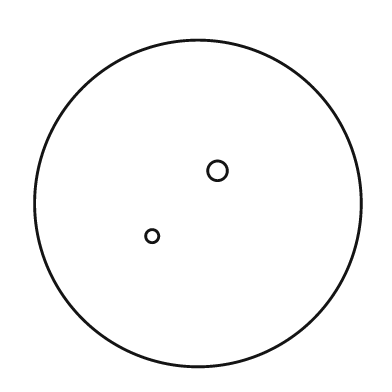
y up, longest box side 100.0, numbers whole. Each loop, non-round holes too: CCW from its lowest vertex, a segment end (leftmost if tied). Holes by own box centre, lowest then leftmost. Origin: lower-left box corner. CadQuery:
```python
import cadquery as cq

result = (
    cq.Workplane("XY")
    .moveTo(50.0, 50.0)
    .circle(50.0)
    .moveTo(36.0, 40.0)
    .circle(2.0)
    .moveTo(56.0, 60.0)
    .circle(3.0)
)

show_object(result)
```